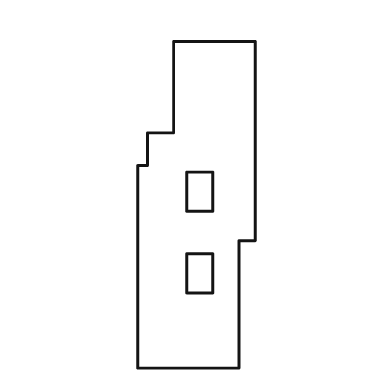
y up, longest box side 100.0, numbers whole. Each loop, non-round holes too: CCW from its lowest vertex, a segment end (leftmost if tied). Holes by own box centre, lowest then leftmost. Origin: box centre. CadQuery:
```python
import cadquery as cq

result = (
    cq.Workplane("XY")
    .moveTo(-18.0, -50.0)
    .lineTo(13.0, -50.0)
    .lineTo(13.0, -11.0)
    .lineTo(18.0, -11.0)
    .lineTo(18.0, 50.0)
    .lineTo(-7.0, 50.0)
    .lineTo(-7.0, 22.0)
    .lineTo(-15.0, 22.0)
    .lineTo(-15.0, 12.0)
    .lineTo(-18.0, 12.0)
    .close()
    .moveTo(-3.0, -27.0)
    .lineTo(5.0, -27.0)
    .lineTo(5.0, -15.0)
    .lineTo(-3.0, -15.0)
    .close()
    .moveTo(-3.0, -2.0)
    .lineTo(5.0, -2.0)
    .lineTo(5.0, 10.0)
    .lineTo(-3.0, 10.0)
    .close()
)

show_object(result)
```